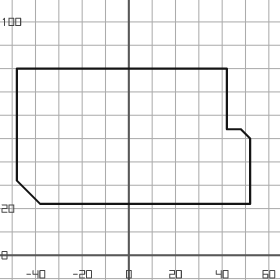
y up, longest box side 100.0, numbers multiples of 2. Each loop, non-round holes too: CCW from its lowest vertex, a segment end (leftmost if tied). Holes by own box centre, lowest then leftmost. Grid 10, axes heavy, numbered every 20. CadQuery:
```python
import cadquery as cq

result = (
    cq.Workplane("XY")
    .moveTo(-38.0, 22.0)
    .lineTo(52.0, 22.0)
    .lineTo(52.0, 50.0)
    .lineTo(48.0, 54.0)
    .lineTo(42.0, 54.0)
    .lineTo(42.0, 80.0)
    .lineTo(-48.0, 80.0)
    .lineTo(-48.0, 32.0)
    .close()
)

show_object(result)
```